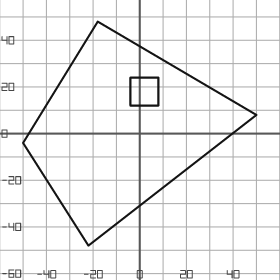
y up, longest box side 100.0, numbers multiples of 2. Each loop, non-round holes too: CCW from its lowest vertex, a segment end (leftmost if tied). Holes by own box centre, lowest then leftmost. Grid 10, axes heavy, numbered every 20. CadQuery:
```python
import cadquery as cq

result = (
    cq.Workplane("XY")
    .moveTo(-22.0, -48.0)
    .lineTo(50.0, 8.0)
    .lineTo(-18.0, 48.0)
    .lineTo(-50.0, -4.0)
    .close()
    .moveTo(-4.0, 12.0)
    .lineTo(8.0, 12.0)
    .lineTo(8.0, 24.0)
    .lineTo(-4.0, 24.0)
    .close()
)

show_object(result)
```